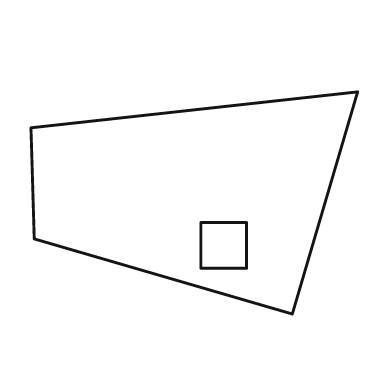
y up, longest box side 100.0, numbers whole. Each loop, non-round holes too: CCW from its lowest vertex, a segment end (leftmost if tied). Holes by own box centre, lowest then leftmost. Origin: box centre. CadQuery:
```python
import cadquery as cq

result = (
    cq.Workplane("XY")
    .moveTo(30.0, -34.0)
    .lineTo(50.0, 34.0)
    .lineTo(-50.0, 23.0)
    .lineTo(-49.0, -11.0)
    .close()
    .moveTo(2.0, -20.0)
    .lineTo(16.0, -20.0)
    .lineTo(16.0, -6.0)
    .lineTo(2.0, -6.0)
    .close()
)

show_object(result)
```